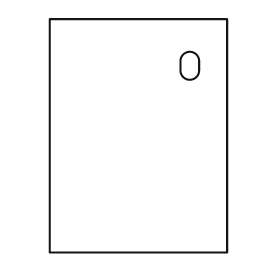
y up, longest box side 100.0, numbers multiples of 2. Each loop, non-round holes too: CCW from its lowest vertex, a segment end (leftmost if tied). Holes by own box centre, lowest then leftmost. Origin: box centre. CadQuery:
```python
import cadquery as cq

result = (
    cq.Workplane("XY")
    .moveTo(-38.0, -50.0)
    .lineTo(38.0, -50.0)
    .lineTo(38.0, 50.0)
    .lineTo(-38.0, 50.0)
    .close()
    .moveTo(18.0, 28.0)
    .threePointArc((22.0, 24.0), (26.0, 28.0))
    .lineTo(26.0, 32.0)
    .threePointArc((22.0, 36.0), (18.0, 32.0))
    .close()
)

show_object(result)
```